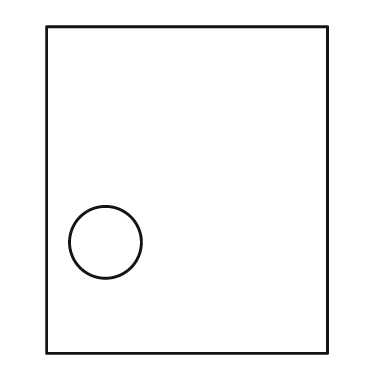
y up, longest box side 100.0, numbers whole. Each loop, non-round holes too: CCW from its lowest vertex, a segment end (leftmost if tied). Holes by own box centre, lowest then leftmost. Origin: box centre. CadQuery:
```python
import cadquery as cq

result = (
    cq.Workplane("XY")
    .moveTo(-43.0, -50.0)
    .lineTo(43.0, -50.0)
    .lineTo(43.0, 50.0)
    .lineTo(-43.0, 50.0)
    .close()
    .moveTo(-25.0, -16.0)
    .circle(11.0)
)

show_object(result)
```